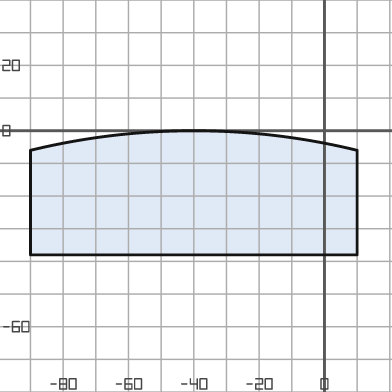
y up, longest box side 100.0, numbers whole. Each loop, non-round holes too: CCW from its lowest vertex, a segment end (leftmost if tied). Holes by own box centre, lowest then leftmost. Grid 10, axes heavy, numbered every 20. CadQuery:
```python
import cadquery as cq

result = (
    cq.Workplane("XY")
    .moveTo(-90.0, -38.0)
    .lineTo(10.0, -38.0)
    .lineTo(10.0, -6.0)
    .threePointArc((-40.0, 0.0), (-90.0, -6.0))
    .close()
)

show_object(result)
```